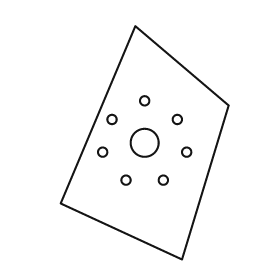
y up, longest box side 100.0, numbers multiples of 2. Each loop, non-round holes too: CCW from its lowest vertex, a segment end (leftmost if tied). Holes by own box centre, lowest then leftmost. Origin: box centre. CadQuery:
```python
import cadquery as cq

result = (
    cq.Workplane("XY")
    .moveTo(16.0, -50.0)
    .lineTo(36.0, 16.0)
    .lineTo(-4.0, 50.0)
    .lineTo(-36.0, -26.0)
    .close()
    .moveTo(-8.0, -16.0)
    .circle(2.0)
    .moveTo(8.0, -16.0)
    .circle(2.0)
    .moveTo(-18.0, -4.0)
    .circle(2.0)
    .moveTo(18.0, -4.0)
    .circle(2.0)
    .moveTo(0.0, 0.0)
    .circle(6.0)
    .moveTo(-14.0, 10.0)
    .circle(2.0)
    .moveTo(14.0, 10.0)
    .circle(2.0)
    .moveTo(0.0, 18.0)
    .circle(2.0)
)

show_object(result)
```